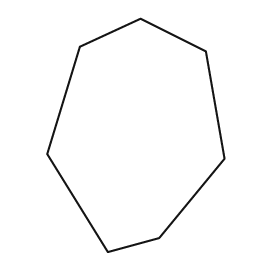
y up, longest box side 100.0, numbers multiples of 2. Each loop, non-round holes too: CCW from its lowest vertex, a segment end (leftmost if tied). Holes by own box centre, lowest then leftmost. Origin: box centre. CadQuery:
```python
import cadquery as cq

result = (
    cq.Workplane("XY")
    .moveTo(-12.0, -50.0)
    .lineTo(10.0, -44.0)
    .lineTo(38.0, -10.0)
    .lineTo(30.0, 36.0)
    .lineTo(2.0, 50.0)
    .lineTo(-24.0, 38.0)
    .lineTo(-38.0, -8.0)
    .close()
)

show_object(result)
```